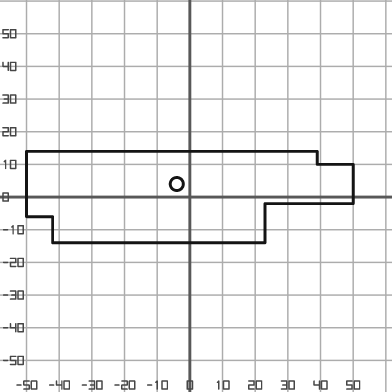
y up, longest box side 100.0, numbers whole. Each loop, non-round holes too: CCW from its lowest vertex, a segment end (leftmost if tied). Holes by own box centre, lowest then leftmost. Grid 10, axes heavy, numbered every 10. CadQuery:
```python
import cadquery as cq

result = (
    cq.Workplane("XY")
    .moveTo(-42.0, -14.0)
    .lineTo(23.0, -14.0)
    .lineTo(23.0, -2.0)
    .lineTo(50.0, -2.0)
    .lineTo(50.0, 10.0)
    .lineTo(39.0, 10.0)
    .lineTo(39.0, 14.0)
    .lineTo(-50.0, 14.0)
    .lineTo(-50.0, -6.0)
    .lineTo(-42.0, -6.0)
    .close()
    .moveTo(-4.0, 4.0)
    .circle(2.0)
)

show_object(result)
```